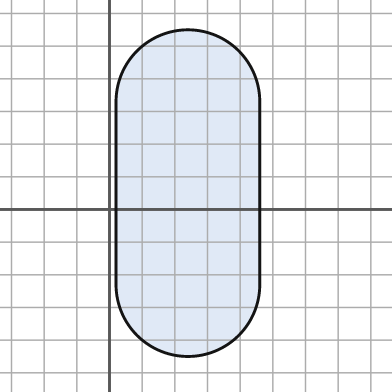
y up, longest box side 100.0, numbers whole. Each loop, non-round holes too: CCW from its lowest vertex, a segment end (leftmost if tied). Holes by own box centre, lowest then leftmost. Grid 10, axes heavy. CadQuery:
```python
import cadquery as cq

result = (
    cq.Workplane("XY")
    .moveTo(2.0, -23.0)
    .threePointArc((24.0, -45.0), (46.0, -23.0))
    .lineTo(46.0, 33.0)
    .threePointArc((24.0, 55.0), (2.0, 33.0))
    .close()
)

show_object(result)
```